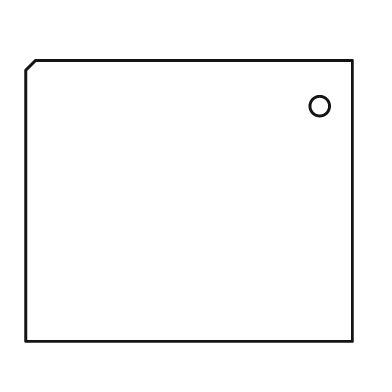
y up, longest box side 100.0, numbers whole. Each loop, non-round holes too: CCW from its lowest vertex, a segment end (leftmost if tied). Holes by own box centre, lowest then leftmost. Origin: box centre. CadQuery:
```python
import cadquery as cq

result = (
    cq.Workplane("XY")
    .moveTo(-50.0, -43.0)
    .lineTo(50.0, -43.0)
    .lineTo(50.0, 43.0)
    .lineTo(-47.0, 43.0)
    .lineTo(-50.0, 40.0)
    .close()
    .moveTo(40.0, 29.0)
    .circle(3.0)
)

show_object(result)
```